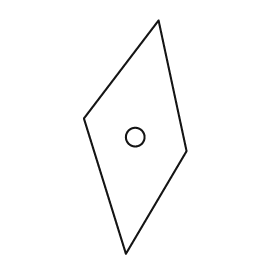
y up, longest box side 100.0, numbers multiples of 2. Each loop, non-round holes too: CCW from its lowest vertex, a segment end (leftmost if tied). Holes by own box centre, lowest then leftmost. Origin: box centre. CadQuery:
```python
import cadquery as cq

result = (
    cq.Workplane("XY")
    .moveTo(-4.0, -50.0)
    .lineTo(22.0, -6.0)
    .lineTo(10.0, 50.0)
    .lineTo(-22.0, 8.0)
    .close()
    .moveTo(0.0, 0.0)
    .circle(4.0)
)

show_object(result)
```